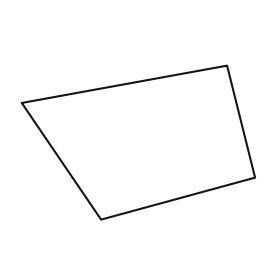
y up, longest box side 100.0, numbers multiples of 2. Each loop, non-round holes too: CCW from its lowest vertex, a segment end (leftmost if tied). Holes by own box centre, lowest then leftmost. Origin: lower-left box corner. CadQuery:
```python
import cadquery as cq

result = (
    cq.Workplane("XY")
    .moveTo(34.0, 0.0)
    .lineTo(100.0, 18.0)
    .lineTo(88.0, 66.0)
    .lineTo(0.0, 50.0)
    .close()
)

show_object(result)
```